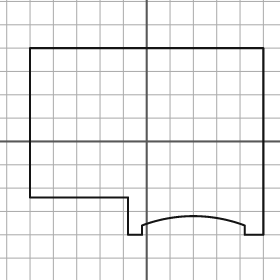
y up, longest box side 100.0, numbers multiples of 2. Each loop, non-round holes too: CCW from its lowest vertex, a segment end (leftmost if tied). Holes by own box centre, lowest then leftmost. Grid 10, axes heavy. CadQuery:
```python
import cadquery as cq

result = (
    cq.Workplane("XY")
    .moveTo(-8.0, -40.0)
    .lineTo(-2.0, -40.0)
    .lineTo(-2.0, -36.0)
    .threePointArc((20.0, -32.0), (42.0, -36.0))
    .lineTo(42.0, -40.0)
    .lineTo(50.0, -40.0)
    .lineTo(50.0, 40.0)
    .lineTo(-50.0, 40.0)
    .lineTo(-50.0, -24.0)
    .lineTo(-8.0, -24.0)
    .close()
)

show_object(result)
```